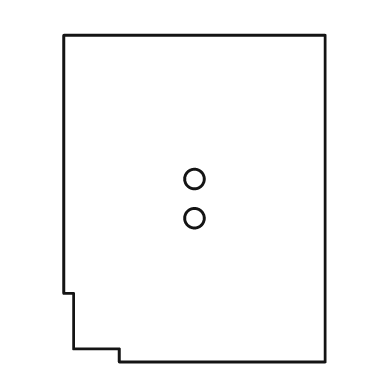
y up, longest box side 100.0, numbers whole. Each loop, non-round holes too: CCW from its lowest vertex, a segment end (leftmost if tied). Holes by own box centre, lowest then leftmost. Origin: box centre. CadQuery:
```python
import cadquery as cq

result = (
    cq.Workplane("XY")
    .moveTo(-23.0, -50.0)
    .lineTo(40.0, -50.0)
    .lineTo(40.0, 50.0)
    .lineTo(-40.0, 50.0)
    .lineTo(-40.0, -29.0)
    .lineTo(-37.0, -29.0)
    .lineTo(-37.0, -46.0)
    .lineTo(-23.0, -46.0)
    .close()
    .moveTo(0.0, -6.0)
    .circle(3.0)
    .moveTo(0.0, 6.0)
    .circle(3.0)
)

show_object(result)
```